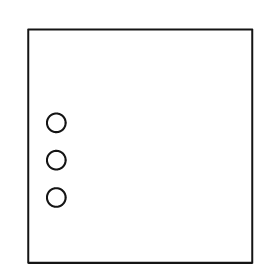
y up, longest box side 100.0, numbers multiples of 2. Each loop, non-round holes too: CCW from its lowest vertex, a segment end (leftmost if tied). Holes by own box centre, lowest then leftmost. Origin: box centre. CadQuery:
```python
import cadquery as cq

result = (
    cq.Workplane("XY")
    .moveTo(-48.0, -50.0)
    .lineTo(48.0, -50.0)
    .lineTo(48.0, 50.0)
    .lineTo(-48.0, 50.0)
    .close()
    .moveTo(-36.0, -22.0)
    .circle(4.0)
    .moveTo(-36.0, -6.0)
    .circle(4.0)
    .moveTo(-36.0, 10.0)
    .circle(4.0)
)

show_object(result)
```